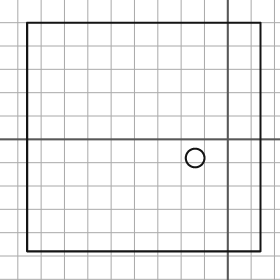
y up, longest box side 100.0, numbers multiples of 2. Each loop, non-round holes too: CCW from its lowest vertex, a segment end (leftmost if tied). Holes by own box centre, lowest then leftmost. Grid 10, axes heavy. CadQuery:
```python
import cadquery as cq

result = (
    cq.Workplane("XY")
    .moveTo(-86.0, -48.0)
    .lineTo(14.0, -48.0)
    .lineTo(14.0, 50.0)
    .lineTo(-86.0, 50.0)
    .close()
    .moveTo(-14.0, -8.0)
    .circle(4.0)
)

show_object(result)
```